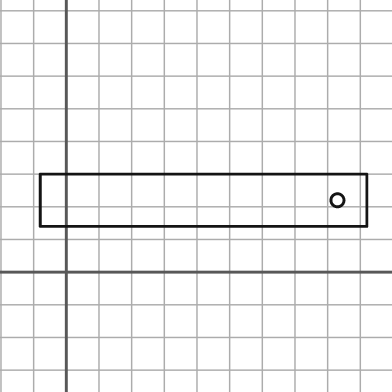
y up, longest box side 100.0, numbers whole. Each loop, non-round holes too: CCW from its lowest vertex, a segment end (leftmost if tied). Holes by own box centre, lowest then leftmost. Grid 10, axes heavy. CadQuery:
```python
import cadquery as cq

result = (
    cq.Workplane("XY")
    .moveTo(-8.0, 14.0)
    .lineTo(92.0, 14.0)
    .lineTo(92.0, 30.0)
    .lineTo(-8.0, 30.0)
    .close()
    .moveTo(83.0, 22.0)
    .circle(2.0)
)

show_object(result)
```